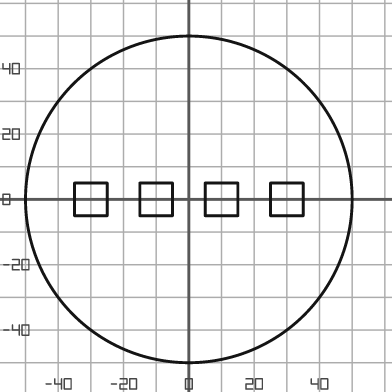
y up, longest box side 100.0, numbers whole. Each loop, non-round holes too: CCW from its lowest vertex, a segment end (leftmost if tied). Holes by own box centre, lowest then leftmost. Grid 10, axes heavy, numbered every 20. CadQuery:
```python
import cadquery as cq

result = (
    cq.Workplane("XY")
    .moveTo(0.0, 0.0)
    .circle(50.0)
    .moveTo(-35.0, -5.0)
    .lineTo(-25.0, -5.0)
    .lineTo(-25.0, 5.0)
    .lineTo(-35.0, 5.0)
    .close()
    .moveTo(-15.0, -5.0)
    .lineTo(-5.0, -5.0)
    .lineTo(-5.0, 5.0)
    .lineTo(-15.0, 5.0)
    .close()
    .moveTo(5.0, -5.0)
    .lineTo(15.0, -5.0)
    .lineTo(15.0, 5.0)
    .lineTo(5.0, 5.0)
    .close()
    .moveTo(25.0, -5.0)
    .lineTo(35.0, -5.0)
    .lineTo(35.0, 5.0)
    .lineTo(25.0, 5.0)
    .close()
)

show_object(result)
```